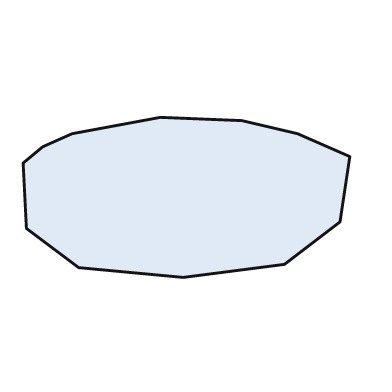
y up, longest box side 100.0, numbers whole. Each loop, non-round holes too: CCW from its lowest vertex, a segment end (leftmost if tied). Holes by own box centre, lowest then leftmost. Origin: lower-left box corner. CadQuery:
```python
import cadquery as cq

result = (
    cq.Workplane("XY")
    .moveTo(49.0, 0.0)
    .lineTo(80.0, 4.0)
    .lineTo(97.0, 17.0)
    .lineTo(100.0, 37.0)
    .lineTo(84.0, 44.0)
    .lineTo(67.0, 48.0)
    .lineTo(42.0, 49.0)
    .lineTo(15.0, 44.0)
    .lineTo(6.0, 40.0)
    .lineTo(0.0, 35.0)
    .lineTo(1.0, 15.0)
    .lineTo(17.0, 3.0)
    .close()
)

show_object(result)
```